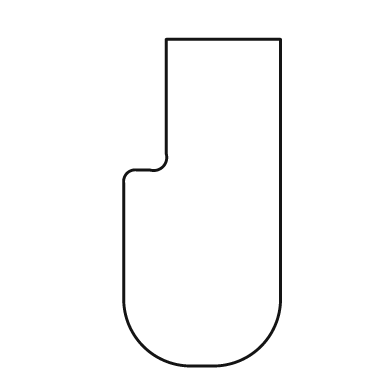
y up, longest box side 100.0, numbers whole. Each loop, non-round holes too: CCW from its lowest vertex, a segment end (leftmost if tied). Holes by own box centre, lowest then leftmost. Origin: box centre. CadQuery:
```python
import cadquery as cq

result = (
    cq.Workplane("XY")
    .moveTo(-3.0, -50.0)
    .lineTo(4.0, -50.0)
    .threePointArc((18.0, -44.0), (24.0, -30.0))
    .lineTo(24.0, 50.0)
    .lineTo(-11.0, 50.0)
    .lineTo(-11.0, 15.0)
    .threePointArc((-12.0, 11.0), (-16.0, 10.0))
    .lineTo(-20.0, 10.0)
    .threePointArc((-23.0, 9.0), (-24.0, 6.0))
    .lineTo(-24.0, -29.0)
    .threePointArc((-18.0, -44.0), (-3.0, -50.0))
    .close()
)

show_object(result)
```